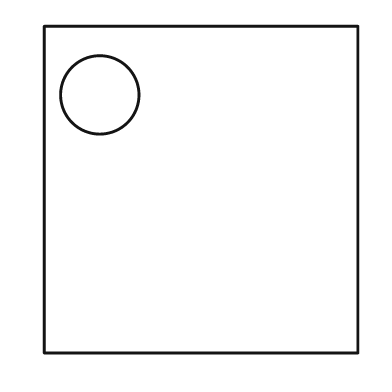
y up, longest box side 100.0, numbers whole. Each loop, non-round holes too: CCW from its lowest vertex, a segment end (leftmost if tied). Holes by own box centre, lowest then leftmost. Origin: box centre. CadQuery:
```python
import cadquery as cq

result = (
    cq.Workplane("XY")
    .moveTo(-48.0, -50.0)
    .lineTo(48.0, -50.0)
    .lineTo(48.0, 50.0)
    .lineTo(-48.0, 50.0)
    .close()
    .moveTo(-31.0, 29.0)
    .circle(12.0)
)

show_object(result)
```